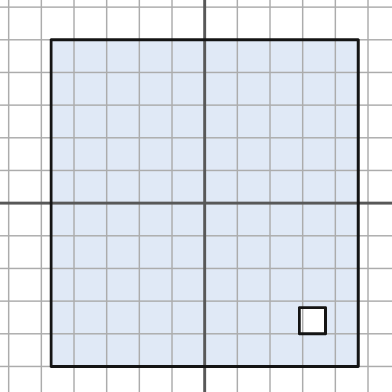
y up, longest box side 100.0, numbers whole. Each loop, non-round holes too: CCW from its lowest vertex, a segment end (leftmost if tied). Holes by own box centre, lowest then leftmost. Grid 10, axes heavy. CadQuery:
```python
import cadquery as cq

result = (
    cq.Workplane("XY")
    .moveTo(-47.0, -50.0)
    .lineTo(47.0, -50.0)
    .lineTo(47.0, 50.0)
    .lineTo(-47.0, 50.0)
    .close()
    .moveTo(29.0, -40.0)
    .lineTo(37.0, -40.0)
    .lineTo(37.0, -32.0)
    .lineTo(29.0, -32.0)
    .close()
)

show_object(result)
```